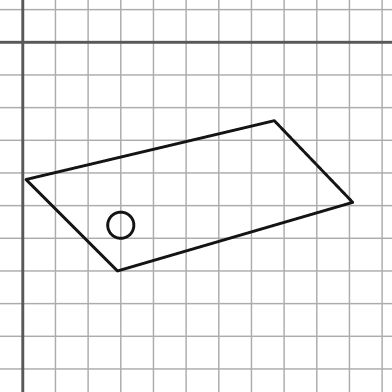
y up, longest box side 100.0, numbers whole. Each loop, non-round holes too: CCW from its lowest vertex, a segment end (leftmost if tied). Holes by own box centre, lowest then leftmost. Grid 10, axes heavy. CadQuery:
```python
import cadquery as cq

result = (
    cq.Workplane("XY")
    .moveTo(29.0, -70.0)
    .lineTo(101.0, -49.0)
    .lineTo(77.0, -24.0)
    .lineTo(1.0, -42.0)
    .close()
    .moveTo(30.0, -56.0)
    .circle(4.0)
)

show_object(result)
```